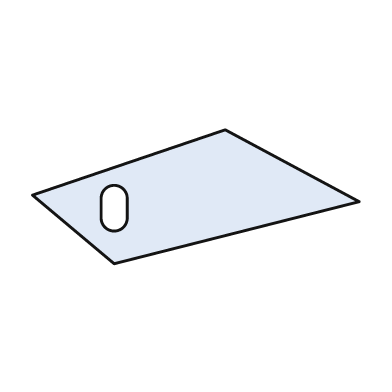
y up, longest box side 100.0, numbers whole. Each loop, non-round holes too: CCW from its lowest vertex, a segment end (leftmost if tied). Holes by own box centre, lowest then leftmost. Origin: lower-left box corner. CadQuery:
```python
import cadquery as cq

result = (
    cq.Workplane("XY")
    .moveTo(25.0, 0.0)
    .lineTo(100.0, 19.0)
    .lineTo(59.0, 41.0)
    .lineTo(0.0, 21.0)
    .close()
    .moveTo(21.0, 14.0)
    .threePointArc((25.0, 10.0), (29.0, 14.0))
    .lineTo(29.0, 20.0)
    .threePointArc((25.0, 24.0), (21.0, 20.0))
    .close()
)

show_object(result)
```